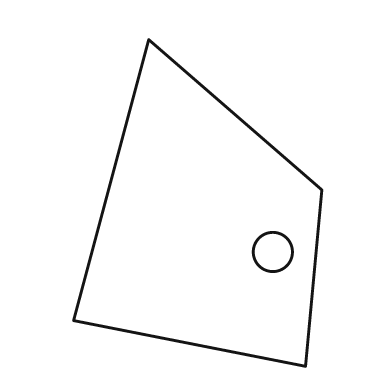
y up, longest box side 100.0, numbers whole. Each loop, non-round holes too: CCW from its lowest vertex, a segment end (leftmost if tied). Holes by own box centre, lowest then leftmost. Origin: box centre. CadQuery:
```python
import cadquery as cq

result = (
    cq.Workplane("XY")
    .moveTo(33.0, -50.0)
    .lineTo(38.0, 4.0)
    .lineTo(-15.0, 50.0)
    .lineTo(-38.0, -36.0)
    .close()
    .moveTo(23.0, -15.0)
    .circle(6.0)
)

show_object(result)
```